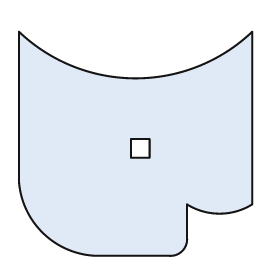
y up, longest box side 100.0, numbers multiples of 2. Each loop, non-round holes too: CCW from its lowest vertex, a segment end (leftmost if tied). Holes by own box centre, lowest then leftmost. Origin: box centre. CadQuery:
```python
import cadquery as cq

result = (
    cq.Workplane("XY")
    .moveTo(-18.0, -48.0)
    .lineTo(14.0, -48.0)
    .threePointArc((20.0, -46.0), (22.0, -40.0))
    .lineTo(22.0, -26.0)
    .threePointArc((36.0, -30.0), (50.0, -26.0))
    .lineTo(50.0, 48.0)
    .threePointArc((0.0, 28.0), (-50.0, 48.0))
    .lineTo(-50.0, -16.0)
    .threePointArc((-40.0, -38.0), (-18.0, -48.0))
    .close()
    .moveTo(-2.0, -6.0)
    .lineTo(6.0, -6.0)
    .lineTo(6.0, 2.0)
    .lineTo(-2.0, 2.0)
    .close()
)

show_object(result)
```